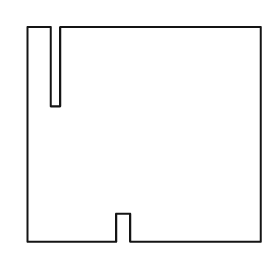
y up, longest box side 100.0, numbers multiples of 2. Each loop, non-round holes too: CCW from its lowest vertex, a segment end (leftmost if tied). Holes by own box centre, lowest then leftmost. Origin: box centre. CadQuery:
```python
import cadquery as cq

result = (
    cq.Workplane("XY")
    .moveTo(-50.0, -46.0)
    .lineTo(-12.0, -46.0)
    .lineTo(-12.0, -34.0)
    .lineTo(-6.0, -34.0)
    .lineTo(-6.0, -46.0)
    .lineTo(50.0, -46.0)
    .lineTo(50.0, 46.0)
    .lineTo(-36.0, 46.0)
    .lineTo(-36.0, 12.0)
    .lineTo(-40.0, 12.0)
    .lineTo(-40.0, 46.0)
    .lineTo(-50.0, 46.0)
    .close()
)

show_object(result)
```